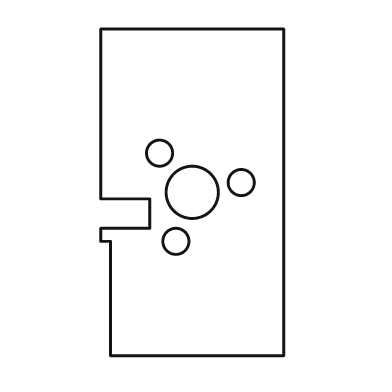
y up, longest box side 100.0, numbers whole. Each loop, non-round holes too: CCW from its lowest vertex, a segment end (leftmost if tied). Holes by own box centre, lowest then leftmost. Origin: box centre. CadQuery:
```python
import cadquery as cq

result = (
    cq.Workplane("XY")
    .moveTo(-25.0, -50.0)
    .lineTo(28.0, -50.0)
    .lineTo(28.0, 50.0)
    .lineTo(-28.0, 50.0)
    .lineTo(-28.0, -2.0)
    .lineTo(-13.0, -2.0)
    .lineTo(-13.0, -11.0)
    .lineTo(-28.0, -11.0)
    .lineTo(-28.0, -15.0)
    .lineTo(-25.0, -15.0)
    .close()
    .moveTo(-5.0, -15.0)
    .circle(4.0)
    .moveTo(0.0, 0.0)
    .circle(8.0)
    .moveTo(15.0, 3.0)
    .circle(4.0)
    .moveTo(-10.0, 12.0)
    .circle(4.0)
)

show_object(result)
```